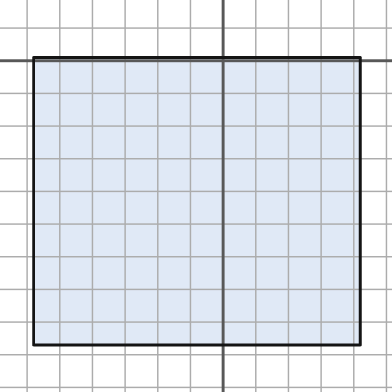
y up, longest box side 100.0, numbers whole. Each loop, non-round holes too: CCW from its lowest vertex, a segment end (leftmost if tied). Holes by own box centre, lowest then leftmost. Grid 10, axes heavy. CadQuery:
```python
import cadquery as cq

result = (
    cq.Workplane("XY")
    .moveTo(-58.0, -87.0)
    .lineTo(42.0, -87.0)
    .lineTo(42.0, 1.0)
    .lineTo(-58.0, 1.0)
    .close()
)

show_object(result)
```